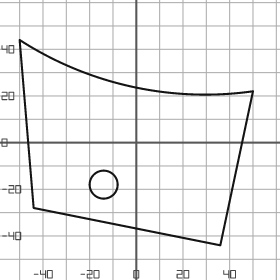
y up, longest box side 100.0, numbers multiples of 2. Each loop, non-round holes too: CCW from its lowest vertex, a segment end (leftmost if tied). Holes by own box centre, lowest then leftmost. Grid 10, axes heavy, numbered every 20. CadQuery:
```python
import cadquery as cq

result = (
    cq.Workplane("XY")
    .moveTo(36.0, -44.0)
    .lineTo(50.0, 22.0)
    .threePointArc((-2.0, 24.0), (-50.0, 44.0))
    .lineTo(-44.0, -28.0)
    .close()
    .moveTo(-14.0, -18.0)
    .circle(6.0)
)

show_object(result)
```